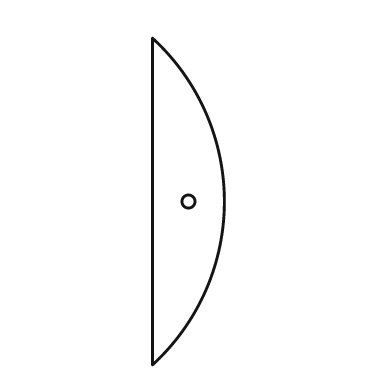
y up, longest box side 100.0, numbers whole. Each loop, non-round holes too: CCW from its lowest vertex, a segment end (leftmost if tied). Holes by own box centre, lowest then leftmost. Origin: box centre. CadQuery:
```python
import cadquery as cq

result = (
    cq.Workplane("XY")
    .moveTo(-11.0, -50.0)
    .threePointArc((11.0, 0.0), (-11.0, 50.0))
    .close()
    .moveTo(0.0, 0.0)
    .circle(2.0)
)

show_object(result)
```